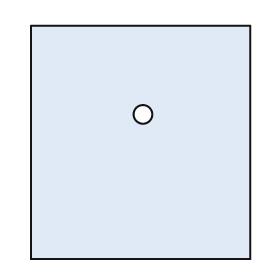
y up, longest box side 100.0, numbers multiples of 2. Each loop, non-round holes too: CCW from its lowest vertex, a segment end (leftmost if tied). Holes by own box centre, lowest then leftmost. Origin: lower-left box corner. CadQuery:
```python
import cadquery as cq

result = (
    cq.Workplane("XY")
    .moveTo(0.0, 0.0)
    .lineTo(94.0, 0.0)
    .lineTo(94.0, 100.0)
    .lineTo(0.0, 100.0)
    .close()
    .moveTo(48.0, 62.0)
    .circle(4.0)
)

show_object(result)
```